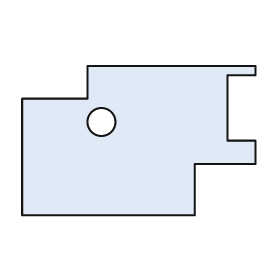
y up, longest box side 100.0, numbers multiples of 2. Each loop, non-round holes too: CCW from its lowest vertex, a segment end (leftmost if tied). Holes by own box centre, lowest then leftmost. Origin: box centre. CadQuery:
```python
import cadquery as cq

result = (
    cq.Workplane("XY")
    .moveTo(-50.0, -32.0)
    .lineTo(24.0, -32.0)
    .lineTo(24.0, -10.0)
    .lineTo(50.0, -10.0)
    .lineTo(50.0, 0.0)
    .lineTo(38.0, 0.0)
    .lineTo(38.0, 28.0)
    .lineTo(50.0, 28.0)
    .lineTo(50.0, 32.0)
    .lineTo(-22.0, 32.0)
    .lineTo(-22.0, 18.0)
    .lineTo(-50.0, 18.0)
    .close()
    .moveTo(-16.0, 8.0)
    .circle(6.0)
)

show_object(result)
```